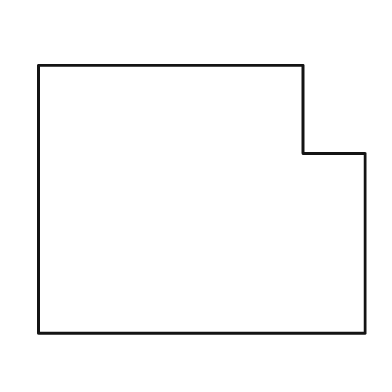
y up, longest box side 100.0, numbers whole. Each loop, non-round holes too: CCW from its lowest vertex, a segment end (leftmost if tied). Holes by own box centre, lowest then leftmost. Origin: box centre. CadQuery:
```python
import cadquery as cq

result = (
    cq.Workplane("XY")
    .moveTo(-50.0, -41.0)
    .lineTo(50.0, -41.0)
    .lineTo(50.0, 14.0)
    .lineTo(31.0, 14.0)
    .lineTo(31.0, 41.0)
    .lineTo(-50.0, 41.0)
    .close()
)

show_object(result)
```